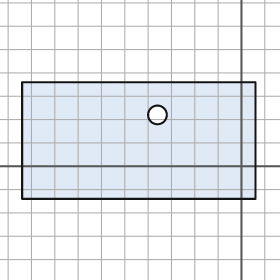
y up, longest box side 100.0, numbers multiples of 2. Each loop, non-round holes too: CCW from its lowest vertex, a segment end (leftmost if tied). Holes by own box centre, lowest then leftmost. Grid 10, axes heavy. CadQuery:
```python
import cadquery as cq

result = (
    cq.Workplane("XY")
    .moveTo(-94.0, -14.0)
    .lineTo(6.0, -14.0)
    .lineTo(6.0, 36.0)
    .lineTo(-94.0, 36.0)
    .close()
    .moveTo(-36.0, 22.0)
    .circle(4.0)
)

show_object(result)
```